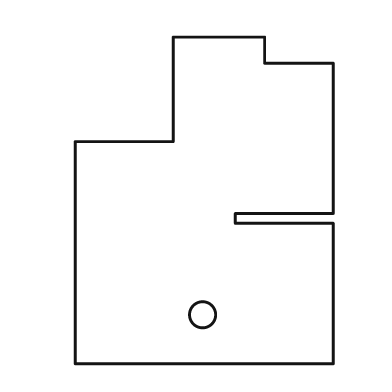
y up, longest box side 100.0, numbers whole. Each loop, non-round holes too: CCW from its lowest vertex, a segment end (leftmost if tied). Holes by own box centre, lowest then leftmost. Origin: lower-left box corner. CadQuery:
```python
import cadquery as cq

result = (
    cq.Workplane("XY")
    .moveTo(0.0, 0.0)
    .lineTo(79.0, 0.0)
    .lineTo(79.0, 43.0)
    .lineTo(49.0, 43.0)
    .lineTo(49.0, 46.0)
    .lineTo(79.0, 46.0)
    .lineTo(79.0, 92.0)
    .lineTo(58.0, 92.0)
    .lineTo(58.0, 100.0)
    .lineTo(30.0, 100.0)
    .lineTo(30.0, 68.0)
    .lineTo(0.0, 68.0)
    .close()
    .moveTo(39.0, 15.0)
    .circle(4.0)
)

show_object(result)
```